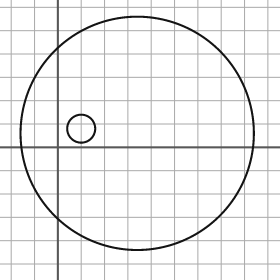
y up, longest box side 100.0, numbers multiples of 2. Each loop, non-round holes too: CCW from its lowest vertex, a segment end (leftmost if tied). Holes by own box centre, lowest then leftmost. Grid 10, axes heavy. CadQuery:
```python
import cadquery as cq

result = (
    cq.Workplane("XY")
    .moveTo(34.0, 6.0)
    .circle(50.0)
    .moveTo(10.0, 8.0)
    .circle(6.0)
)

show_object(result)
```